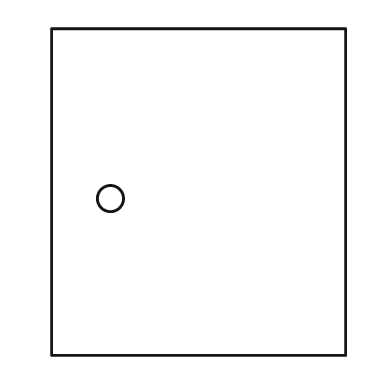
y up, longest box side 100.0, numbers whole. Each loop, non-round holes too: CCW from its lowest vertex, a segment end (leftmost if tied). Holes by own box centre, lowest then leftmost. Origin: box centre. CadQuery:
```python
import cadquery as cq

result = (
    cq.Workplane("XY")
    .moveTo(-45.0, -50.0)
    .lineTo(45.0, -50.0)
    .lineTo(45.0, 50.0)
    .lineTo(-45.0, 50.0)
    .close()
    .moveTo(-27.0, -2.0)
    .circle(4.0)
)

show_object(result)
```